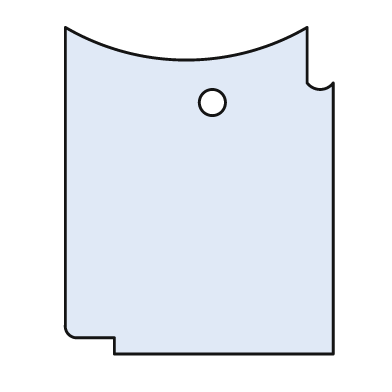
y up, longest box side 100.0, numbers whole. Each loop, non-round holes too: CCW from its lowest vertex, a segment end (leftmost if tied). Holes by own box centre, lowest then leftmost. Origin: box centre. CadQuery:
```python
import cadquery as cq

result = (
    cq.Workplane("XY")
    .moveTo(-26.0, -50.0)
    .lineTo(41.0, -50.0)
    .lineTo(41.0, 33.0)
    .threePointArc((37.0, 31.0), (33.0, 33.0))
    .lineTo(33.0, 50.0)
    .threePointArc((-4.0, 40.0), (-41.0, 50.0))
    .lineTo(-41.0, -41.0)
    .threePointArc((-40.0, -44.0), (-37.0, -45.0))
    .lineTo(-26.0, -45.0)
    .close()
    .moveTo(4.0, 27.0)
    .circle(4.0)
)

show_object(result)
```